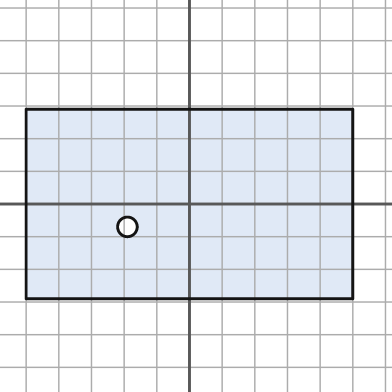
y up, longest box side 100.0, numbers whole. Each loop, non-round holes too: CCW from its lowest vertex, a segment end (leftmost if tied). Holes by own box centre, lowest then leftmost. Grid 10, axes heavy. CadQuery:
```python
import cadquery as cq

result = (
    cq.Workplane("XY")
    .moveTo(-50.0, -29.0)
    .lineTo(50.0, -29.0)
    .lineTo(50.0, 29.0)
    .lineTo(-50.0, 29.0)
    .close()
    .moveTo(-19.0, -7.0)
    .circle(3.0)
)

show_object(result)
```